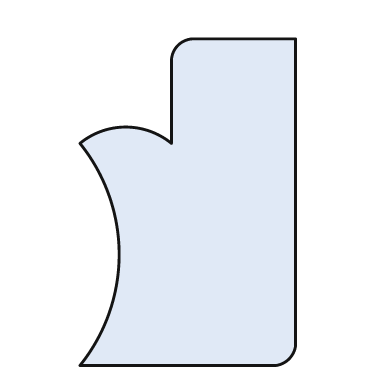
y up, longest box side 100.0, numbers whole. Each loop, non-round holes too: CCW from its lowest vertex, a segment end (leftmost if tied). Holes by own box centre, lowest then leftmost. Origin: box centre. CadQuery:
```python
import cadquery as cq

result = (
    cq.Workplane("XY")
    .moveTo(-33.0, -50.0)
    .lineTo(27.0, -50.0)
    .threePointArc((31.0, -48.0), (33.0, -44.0))
    .lineTo(33.0, 50.0)
    .lineTo(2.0, 50.0)
    .threePointArc((-3.0, 48.0), (-5.0, 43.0))
    .lineTo(-5.0, 18.0)
    .threePointArc((-19.0, 23.0), (-33.0, 18.0))
    .threePointArc((-21.0, -16.0), (-33.0, -50.0))
    .close()
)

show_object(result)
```